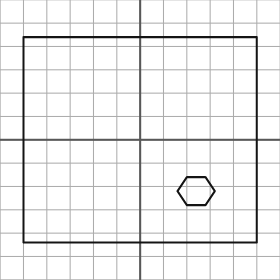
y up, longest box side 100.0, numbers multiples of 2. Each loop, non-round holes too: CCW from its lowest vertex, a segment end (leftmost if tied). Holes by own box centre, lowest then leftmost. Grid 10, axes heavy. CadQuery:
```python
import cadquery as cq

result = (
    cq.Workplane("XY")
    .moveTo(-50.0, -44.0)
    .lineTo(50.0, -44.0)
    .lineTo(50.0, 44.0)
    .lineTo(-50.0, 44.0)
    .close()
    .moveTo(20.0, -28.0)
    .lineTo(28.0, -28.0)
    .lineTo(32.0, -22.0)
    .lineTo(28.0, -16.0)
    .lineTo(20.0, -16.0)
    .lineTo(16.0, -22.0)
    .close()
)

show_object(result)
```